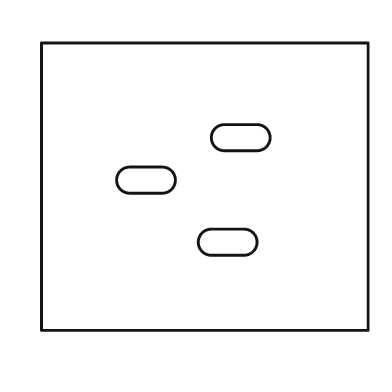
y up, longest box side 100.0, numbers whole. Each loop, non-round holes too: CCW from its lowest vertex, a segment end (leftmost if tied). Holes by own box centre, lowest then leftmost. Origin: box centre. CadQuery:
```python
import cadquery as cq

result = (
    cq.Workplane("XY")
    .moveTo(-50.0, -44.0)
    .lineTo(50.0, -44.0)
    .lineTo(50.0, 44.0)
    .lineTo(-50.0, 44.0)
    .close()
    .moveTo(2.0, -21.0)
    .lineTo(12.0, -21.0)
    .threePointArc((16.0, -17.0), (12.0, -13.0))
    .lineTo(2.0, -13.0)
    .threePointArc((-2.0, -17.0), (2.0, -21.0))
    .close()
    .moveTo(-23.0, -2.0)
    .lineTo(-13.0, -2.0)
    .threePointArc((-9.0, 2.0), (-13.0, 6.0))
    .lineTo(-23.0, 6.0)
    .threePointArc((-27.0, 2.0), (-23.0, -2.0))
    .close()
    .moveTo(6.0, 11.0)
    .lineTo(16.0, 11.0)
    .threePointArc((20.0, 15.0), (16.0, 19.0))
    .lineTo(6.0, 19.0)
    .threePointArc((2.0, 15.0), (6.0, 11.0))
    .close()
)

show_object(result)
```